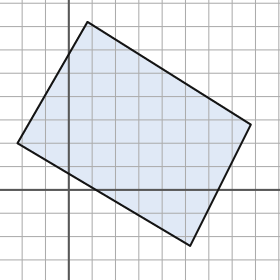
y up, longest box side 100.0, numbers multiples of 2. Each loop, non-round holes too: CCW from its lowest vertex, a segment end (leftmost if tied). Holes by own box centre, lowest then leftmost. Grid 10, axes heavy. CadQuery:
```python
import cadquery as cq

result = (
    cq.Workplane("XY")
    .moveTo(52.0, -24.0)
    .lineTo(78.0, 28.0)
    .lineTo(8.0, 72.0)
    .lineTo(-22.0, 20.0)
    .close()
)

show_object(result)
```